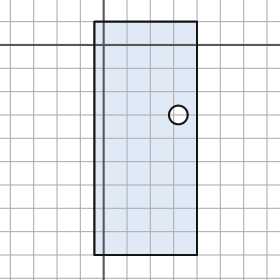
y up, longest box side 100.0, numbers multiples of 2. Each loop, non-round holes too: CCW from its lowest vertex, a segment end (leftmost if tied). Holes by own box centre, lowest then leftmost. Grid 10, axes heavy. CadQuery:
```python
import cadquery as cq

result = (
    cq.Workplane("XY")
    .moveTo(-4.0, -90.0)
    .lineTo(40.0, -90.0)
    .lineTo(40.0, 10.0)
    .lineTo(-4.0, 10.0)
    .close()
    .moveTo(32.0, -30.0)
    .circle(4.0)
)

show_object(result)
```